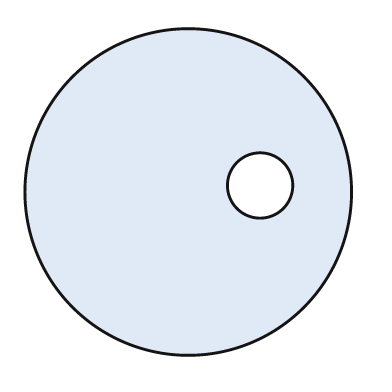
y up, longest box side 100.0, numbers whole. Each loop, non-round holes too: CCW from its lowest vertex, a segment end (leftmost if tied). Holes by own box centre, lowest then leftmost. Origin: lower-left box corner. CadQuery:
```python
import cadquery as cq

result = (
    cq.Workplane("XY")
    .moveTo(50.0, 50.0)
    .circle(50.0)
    .moveTo(72.0, 52.0)
    .circle(10.0)
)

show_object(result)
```